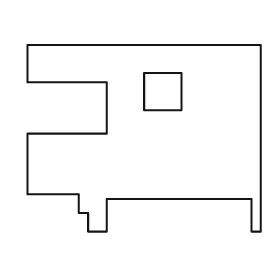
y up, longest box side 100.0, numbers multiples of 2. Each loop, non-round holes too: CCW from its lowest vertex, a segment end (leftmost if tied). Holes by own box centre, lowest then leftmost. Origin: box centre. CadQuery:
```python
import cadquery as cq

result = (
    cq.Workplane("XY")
    .moveTo(-24.0, -40.0)
    .lineTo(-16.0, -40.0)
    .lineTo(-16.0, -26.0)
    .lineTo(46.0, -26.0)
    .lineTo(46.0, -40.0)
    .lineTo(50.0, -40.0)
    .lineTo(50.0, 40.0)
    .lineTo(-50.0, 40.0)
    .lineTo(-50.0, 24.0)
    .lineTo(-16.0, 24.0)
    .lineTo(-16.0, 2.0)
    .lineTo(-50.0, 2.0)
    .lineTo(-50.0, -24.0)
    .lineTo(-28.0, -24.0)
    .lineTo(-28.0, -32.0)
    .lineTo(-24.0, -32.0)
    .close()
    .moveTo(0.0, 12.0)
    .lineTo(16.0, 12.0)
    .lineTo(16.0, 28.0)
    .lineTo(0.0, 28.0)
    .close()
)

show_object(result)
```